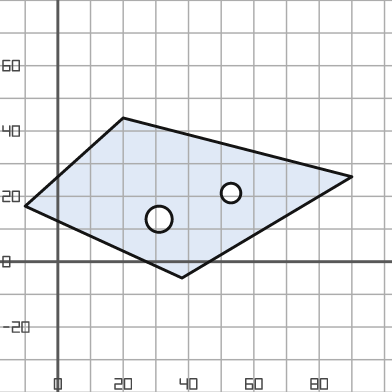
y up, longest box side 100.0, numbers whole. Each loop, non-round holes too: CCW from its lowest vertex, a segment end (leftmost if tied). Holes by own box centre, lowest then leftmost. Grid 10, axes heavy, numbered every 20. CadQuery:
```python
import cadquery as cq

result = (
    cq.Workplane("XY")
    .moveTo(38.0, -5.0)
    .lineTo(90.0, 26.0)
    .lineTo(20.0, 44.0)
    .lineTo(-10.0, 17.0)
    .close()
    .moveTo(31.0, 13.0)
    .circle(4.0)
    .moveTo(53.0, 21.0)
    .circle(3.0)
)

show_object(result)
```